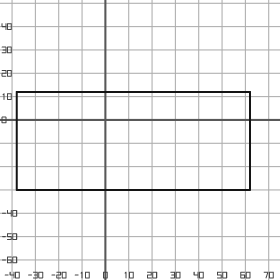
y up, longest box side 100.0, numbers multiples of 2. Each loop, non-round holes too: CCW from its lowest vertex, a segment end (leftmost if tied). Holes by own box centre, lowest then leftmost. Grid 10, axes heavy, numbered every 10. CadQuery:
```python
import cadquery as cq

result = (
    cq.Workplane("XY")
    .moveTo(-38.0, -30.0)
    .lineTo(62.0, -30.0)
    .lineTo(62.0, 12.0)
    .lineTo(-38.0, 12.0)
    .close()
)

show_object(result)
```